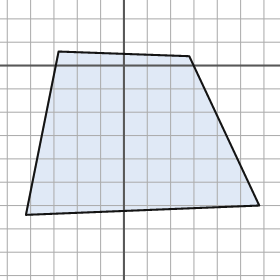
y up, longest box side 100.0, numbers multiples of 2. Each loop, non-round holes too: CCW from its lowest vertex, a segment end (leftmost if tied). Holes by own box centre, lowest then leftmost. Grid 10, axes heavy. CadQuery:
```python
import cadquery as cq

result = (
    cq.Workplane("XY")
    .moveTo(-42.0, -64.0)
    .lineTo(58.0, -60.0)
    .lineTo(28.0, 4.0)
    .lineTo(-28.0, 6.0)
    .close()
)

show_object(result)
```